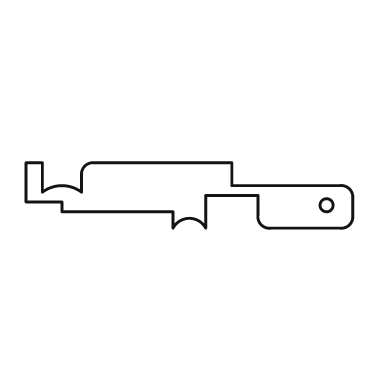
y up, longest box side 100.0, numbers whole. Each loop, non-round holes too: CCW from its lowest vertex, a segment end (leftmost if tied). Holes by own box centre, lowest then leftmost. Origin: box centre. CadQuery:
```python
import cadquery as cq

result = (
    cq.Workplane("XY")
    .moveTo(-5.0, -10.0)
    .threePointArc((0.0, -7.0), (5.0, -10.0))
    .lineTo(5.0, 0.0)
    .lineTo(21.0, 0.0)
    .lineTo(21.0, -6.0)
    .threePointArc((22.0, -9.0), (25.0, -10.0))
    .lineTo(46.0, -10.0)
    .threePointArc((49.0, -9.0), (50.0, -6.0))
    .lineTo(50.0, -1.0)
    .threePointArc((49.0, 2.0), (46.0, 3.0))
    .lineTo(13.0, 3.0)
    .lineTo(13.0, 10.0)
    .lineTo(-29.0, 10.0)
    .threePointArc((-32.0, 9.0), (-33.0, 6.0))
    .lineTo(-33.0, 1.0)
    .threePointArc((-39.0, 3.0), (-45.0, 1.0))
    .lineTo(-45.0, 10.0)
    .lineTo(-50.0, 10.0)
    .lineTo(-50.0, -2.0)
    .lineTo(-39.0, -2.0)
    .lineTo(-39.0, -5.0)
    .lineTo(-5.0, -5.0)
    .close()
    .moveTo(42.0, -3.0)
    .circle(2.0)
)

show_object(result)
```